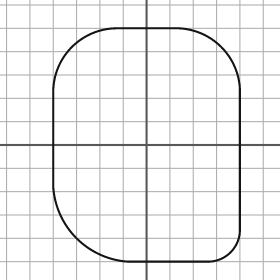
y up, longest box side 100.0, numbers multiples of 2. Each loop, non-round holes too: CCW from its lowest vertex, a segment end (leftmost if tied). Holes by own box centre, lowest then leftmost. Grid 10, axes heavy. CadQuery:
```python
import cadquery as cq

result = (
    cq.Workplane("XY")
    .moveTo(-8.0, -50.0)
    .lineTo(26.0, -50.0)
    .threePointArc((36.0, -46.0), (40.0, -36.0))
    .lineTo(40.0, 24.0)
    .threePointArc((32.0, 42.0), (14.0, 50.0))
    .lineTo(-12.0, 50.0)
    .threePointArc((-32.0, 42.0), (-40.0, 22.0))
    .lineTo(-40.0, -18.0)
    .threePointArc((-30.0, -40.0), (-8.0, -50.0))
    .close()
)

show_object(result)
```